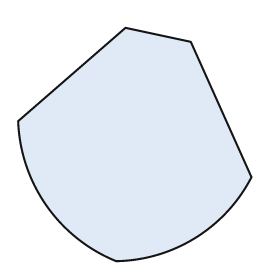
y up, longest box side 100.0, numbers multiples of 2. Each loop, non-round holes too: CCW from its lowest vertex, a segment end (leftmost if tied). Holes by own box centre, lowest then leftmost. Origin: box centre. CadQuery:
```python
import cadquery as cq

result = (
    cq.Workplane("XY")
    .moveTo(-8.0, -50.0)
    .threePointArc((26.0, -40.0), (50.0, -14.0))
    .lineTo(24.0, 44.0)
    .lineTo(-4.0, 50.0)
    .lineTo(-50.0, 10.0)
    .threePointArc((-38.0, -26.0), (-8.0, -50.0))
    .close()
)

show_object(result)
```